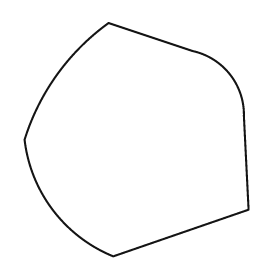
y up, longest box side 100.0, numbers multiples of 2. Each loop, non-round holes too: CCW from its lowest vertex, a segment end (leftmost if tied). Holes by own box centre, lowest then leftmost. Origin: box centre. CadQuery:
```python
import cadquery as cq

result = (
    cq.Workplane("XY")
    .moveTo(-10.0, -50.0)
    .lineTo(48.0, -30.0)
    .lineTo(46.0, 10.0)
    .threePointArc((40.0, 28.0), (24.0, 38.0))
    .lineTo(-12.0, 50.0)
    .threePointArc((-34.0, 28.0), (-48.0, 0.0))
    .threePointArc((-36.0, -30.0), (-10.0, -50.0))
    .close()
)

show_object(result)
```